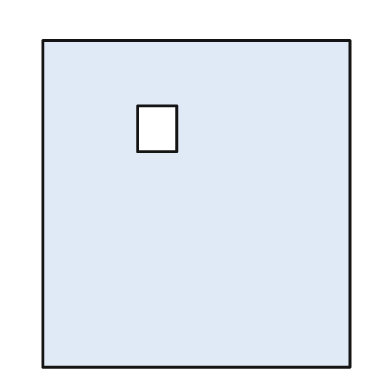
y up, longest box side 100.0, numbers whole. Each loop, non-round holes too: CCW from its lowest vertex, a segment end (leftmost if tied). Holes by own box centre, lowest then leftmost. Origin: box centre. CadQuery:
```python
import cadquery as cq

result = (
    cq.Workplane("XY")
    .moveTo(-47.0, -50.0)
    .lineTo(47.0, -50.0)
    .lineTo(47.0, 50.0)
    .lineTo(-47.0, 50.0)
    .close()
    .moveTo(-18.0, 16.0)
    .lineTo(-6.0, 16.0)
    .lineTo(-6.0, 30.0)
    .lineTo(-18.0, 30.0)
    .close()
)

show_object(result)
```